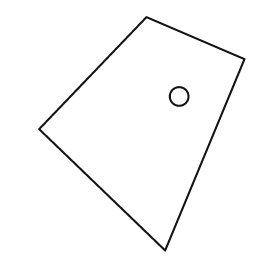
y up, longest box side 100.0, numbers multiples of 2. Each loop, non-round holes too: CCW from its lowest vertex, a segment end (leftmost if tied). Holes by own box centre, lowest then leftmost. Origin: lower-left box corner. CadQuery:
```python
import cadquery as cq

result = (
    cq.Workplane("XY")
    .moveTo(54.0, 0.0)
    .lineTo(88.0, 82.0)
    .lineTo(46.0, 100.0)
    .lineTo(0.0, 52.0)
    .close()
    .moveTo(60.0, 66.0)
    .circle(4.0)
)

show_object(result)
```